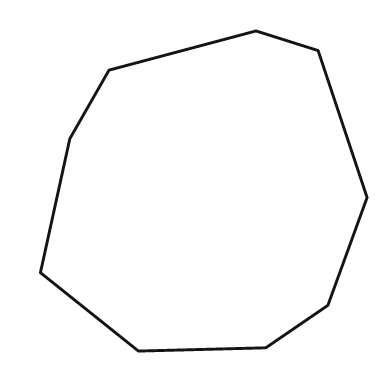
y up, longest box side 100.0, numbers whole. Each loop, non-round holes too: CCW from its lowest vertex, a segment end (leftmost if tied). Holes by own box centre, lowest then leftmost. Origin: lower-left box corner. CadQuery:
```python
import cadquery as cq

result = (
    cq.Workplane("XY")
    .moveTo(30.0, 0.0)
    .lineTo(69.0, 1.0)
    .lineTo(88.0, 14.0)
    .lineTo(100.0, 47.0)
    .lineTo(85.0, 92.0)
    .lineTo(66.0, 98.0)
    .lineTo(21.0, 86.0)
    .lineTo(9.0, 65.0)
    .lineTo(0.0, 24.0)
    .close()
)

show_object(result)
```